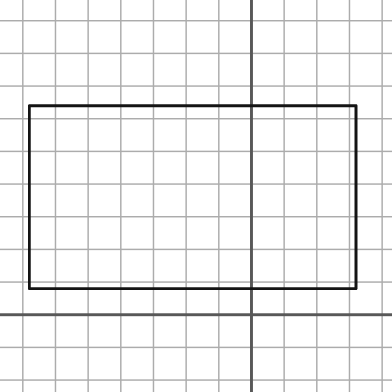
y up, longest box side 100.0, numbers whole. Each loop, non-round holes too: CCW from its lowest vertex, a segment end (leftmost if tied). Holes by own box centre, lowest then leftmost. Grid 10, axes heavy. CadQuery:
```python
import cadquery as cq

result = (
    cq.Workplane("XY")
    .moveTo(-68.0, 8.0)
    .lineTo(32.0, 8.0)
    .lineTo(32.0, 64.0)
    .lineTo(-68.0, 64.0)
    .close()
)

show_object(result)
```